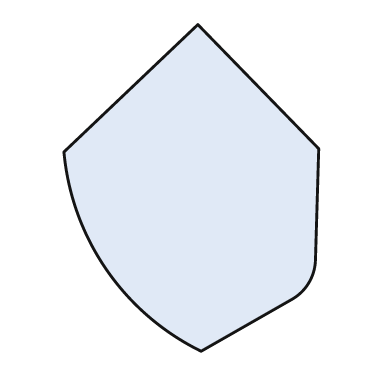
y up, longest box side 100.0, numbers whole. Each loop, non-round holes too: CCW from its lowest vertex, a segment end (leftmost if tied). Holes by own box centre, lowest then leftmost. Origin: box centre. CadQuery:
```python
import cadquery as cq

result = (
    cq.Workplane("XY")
    .moveTo(3.0, -50.0)
    .lineTo(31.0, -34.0)
    .threePointArc((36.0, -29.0), (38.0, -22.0))
    .lineTo(39.0, 12.0)
    .lineTo(2.0, 50.0)
    .lineTo(-39.0, 11.0)
    .threePointArc((-26.0, -25.0), (3.0, -50.0))
    .close()
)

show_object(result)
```